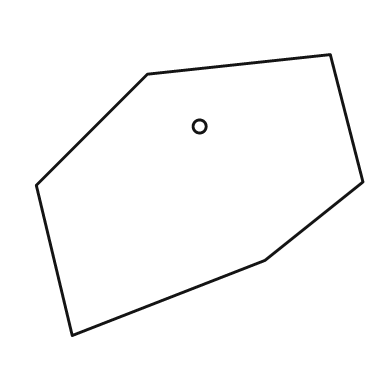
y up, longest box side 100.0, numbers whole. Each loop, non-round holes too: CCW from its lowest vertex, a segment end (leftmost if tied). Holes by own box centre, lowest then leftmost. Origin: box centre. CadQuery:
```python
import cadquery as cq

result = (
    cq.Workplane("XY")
    .moveTo(-39.0, -43.0)
    .lineTo(20.0, -20.0)
    .lineTo(50.0, 4.0)
    .lineTo(40.0, 43.0)
    .lineTo(-16.0, 37.0)
    .lineTo(-50.0, 3.0)
    .close()
    .moveTo(0.0, 21.0)
    .circle(2.0)
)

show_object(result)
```